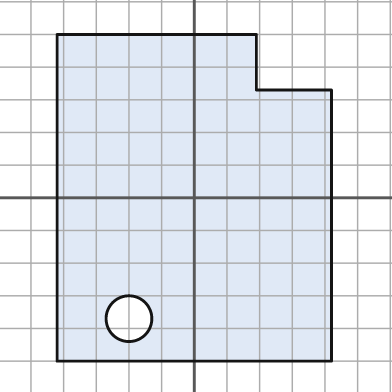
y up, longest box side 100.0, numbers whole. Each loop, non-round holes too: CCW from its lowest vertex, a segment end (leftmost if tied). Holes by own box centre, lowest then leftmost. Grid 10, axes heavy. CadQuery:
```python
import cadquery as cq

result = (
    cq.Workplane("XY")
    .moveTo(-42.0, -50.0)
    .lineTo(42.0, -50.0)
    .lineTo(42.0, 33.0)
    .lineTo(19.0, 33.0)
    .lineTo(19.0, 50.0)
    .lineTo(-42.0, 50.0)
    .close()
    .moveTo(-20.0, -37.0)
    .circle(7.0)
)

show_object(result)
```